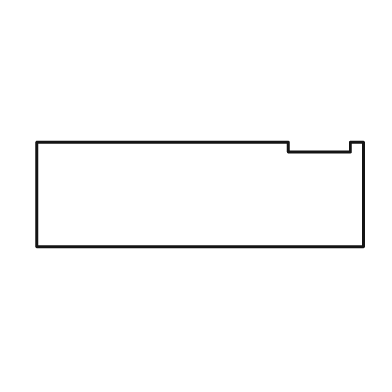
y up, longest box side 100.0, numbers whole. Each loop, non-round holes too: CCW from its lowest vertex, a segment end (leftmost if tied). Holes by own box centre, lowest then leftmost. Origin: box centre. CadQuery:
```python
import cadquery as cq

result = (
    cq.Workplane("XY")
    .moveTo(-50.0, -16.0)
    .lineTo(50.0, -16.0)
    .lineTo(50.0, 16.0)
    .lineTo(46.0, 16.0)
    .lineTo(46.0, 13.0)
    .lineTo(27.0, 13.0)
    .lineTo(27.0, 16.0)
    .lineTo(-50.0, 16.0)
    .close()
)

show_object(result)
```